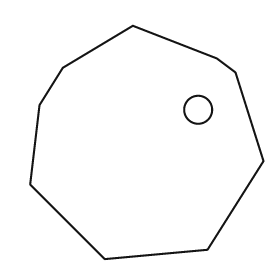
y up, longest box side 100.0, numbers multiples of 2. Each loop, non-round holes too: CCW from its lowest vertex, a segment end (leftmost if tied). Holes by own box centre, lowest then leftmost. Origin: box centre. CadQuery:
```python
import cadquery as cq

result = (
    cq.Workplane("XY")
    .moveTo(-18.0, -50.0)
    .lineTo(26.0, -46.0)
    .lineTo(50.0, -8.0)
    .lineTo(38.0, 30.0)
    .lineTo(30.0, 36.0)
    .lineTo(-6.0, 50.0)
    .lineTo(-36.0, 32.0)
    .lineTo(-46.0, 16.0)
    .lineTo(-50.0, -18.0)
    .close()
    .moveTo(22.0, 14.0)
    .circle(6.0)
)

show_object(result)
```